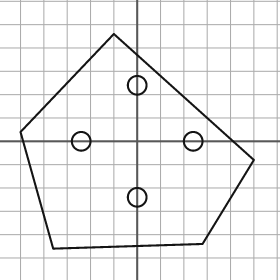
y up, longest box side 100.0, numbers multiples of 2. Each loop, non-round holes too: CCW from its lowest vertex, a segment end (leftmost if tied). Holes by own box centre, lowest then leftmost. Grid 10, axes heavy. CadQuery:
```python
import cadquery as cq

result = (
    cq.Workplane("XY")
    .moveTo(-36.0, -46.0)
    .lineTo(28.0, -44.0)
    .lineTo(50.0, -8.0)
    .lineTo(-10.0, 46.0)
    .lineTo(-50.0, 4.0)
    .close()
    .moveTo(0.0, -24.0)
    .circle(4.0)
    .moveTo(-24.0, 0.0)
    .circle(4.0)
    .moveTo(24.0, 0.0)
    .circle(4.0)
    .moveTo(0.0, 24.0)
    .circle(4.0)
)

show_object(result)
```